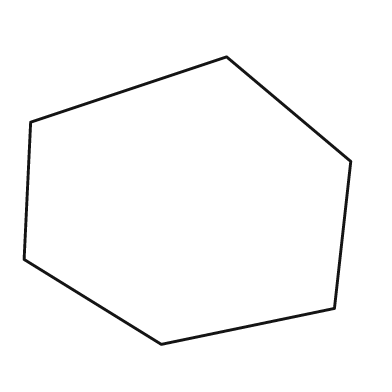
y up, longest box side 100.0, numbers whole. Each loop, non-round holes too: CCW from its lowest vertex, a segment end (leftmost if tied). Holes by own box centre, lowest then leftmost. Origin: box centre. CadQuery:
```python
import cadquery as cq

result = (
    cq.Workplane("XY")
    .moveTo(-8.0, -44.0)
    .lineTo(45.0, -33.0)
    .lineTo(50.0, 12.0)
    .lineTo(12.0, 44.0)
    .lineTo(-48.0, 24.0)
    .lineTo(-50.0, -18.0)
    .close()
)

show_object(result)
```